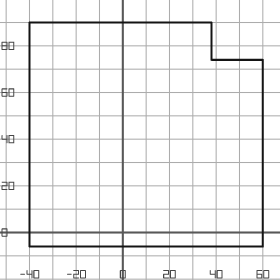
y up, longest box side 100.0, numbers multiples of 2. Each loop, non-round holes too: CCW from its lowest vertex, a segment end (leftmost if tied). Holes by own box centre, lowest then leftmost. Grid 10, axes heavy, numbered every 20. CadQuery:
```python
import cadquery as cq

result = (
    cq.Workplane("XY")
    .moveTo(-40.0, -6.0)
    .lineTo(60.0, -6.0)
    .lineTo(60.0, 74.0)
    .lineTo(38.0, 74.0)
    .lineTo(38.0, 90.0)
    .lineTo(-40.0, 90.0)
    .close()
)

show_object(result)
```